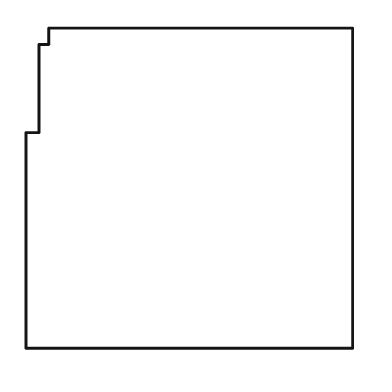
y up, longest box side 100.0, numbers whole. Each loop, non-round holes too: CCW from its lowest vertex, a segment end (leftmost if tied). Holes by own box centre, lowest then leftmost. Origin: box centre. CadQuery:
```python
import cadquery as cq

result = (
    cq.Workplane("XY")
    .moveTo(-50.0, -49.0)
    .lineTo(50.0, -49.0)
    .lineTo(50.0, 49.0)
    .lineTo(-43.0, 49.0)
    .lineTo(-43.0, 44.0)
    .lineTo(-46.0, 44.0)
    .lineTo(-46.0, 17.0)
    .lineTo(-50.0, 17.0)
    .close()
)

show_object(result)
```